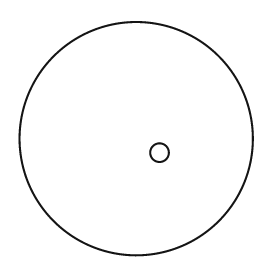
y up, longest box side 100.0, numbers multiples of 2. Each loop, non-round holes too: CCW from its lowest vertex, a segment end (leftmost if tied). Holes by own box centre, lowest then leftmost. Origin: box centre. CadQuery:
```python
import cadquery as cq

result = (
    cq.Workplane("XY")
    .moveTo(0.0, 0.0)
    .circle(50.0)
    .moveTo(10.0, -6.0)
    .circle(4.0)
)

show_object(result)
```